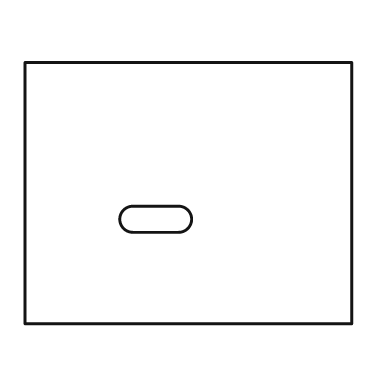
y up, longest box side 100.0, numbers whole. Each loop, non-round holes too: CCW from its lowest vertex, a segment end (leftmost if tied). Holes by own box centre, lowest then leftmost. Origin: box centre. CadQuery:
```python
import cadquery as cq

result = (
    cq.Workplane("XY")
    .moveTo(-50.0, -40.0)
    .lineTo(50.0, -40.0)
    .lineTo(50.0, 40.0)
    .lineTo(-50.0, 40.0)
    .close()
    .moveTo(-17.0, -12.0)
    .lineTo(-3.0, -12.0)
    .threePointArc((1.0, -8.0), (-3.0, -4.0))
    .lineTo(-17.0, -4.0)
    .threePointArc((-21.0, -8.0), (-17.0, -12.0))
    .close()
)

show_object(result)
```